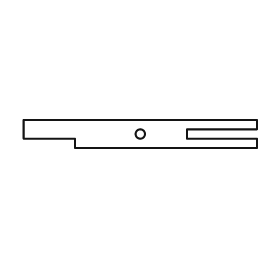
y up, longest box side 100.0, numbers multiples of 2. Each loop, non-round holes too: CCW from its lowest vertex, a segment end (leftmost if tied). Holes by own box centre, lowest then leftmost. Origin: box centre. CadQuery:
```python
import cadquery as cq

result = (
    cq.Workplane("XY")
    .moveTo(-28.0, -6.0)
    .lineTo(50.0, -6.0)
    .lineTo(50.0, -2.0)
    .lineTo(20.0, -2.0)
    .lineTo(20.0, 2.0)
    .lineTo(50.0, 2.0)
    .lineTo(50.0, 6.0)
    .lineTo(-50.0, 6.0)
    .lineTo(-50.0, -2.0)
    .lineTo(-28.0, -2.0)
    .close()
    .moveTo(0.0, 0.0)
    .circle(2.0)
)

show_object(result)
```